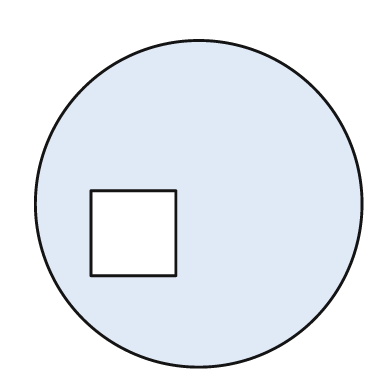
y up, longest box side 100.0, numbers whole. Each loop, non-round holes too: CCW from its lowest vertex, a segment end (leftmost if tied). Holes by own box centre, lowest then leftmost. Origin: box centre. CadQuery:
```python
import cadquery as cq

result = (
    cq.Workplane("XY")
    .moveTo(0.0, 0.0)
    .circle(50.0)
    .moveTo(-33.0, -22.0)
    .lineTo(-7.0, -22.0)
    .lineTo(-7.0, 4.0)
    .lineTo(-33.0, 4.0)
    .close()
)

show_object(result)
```